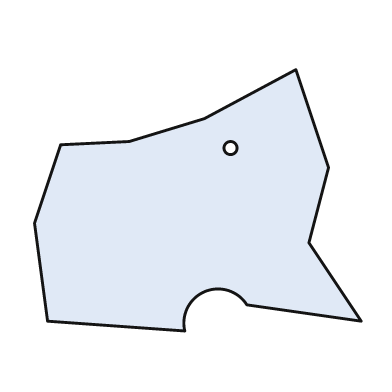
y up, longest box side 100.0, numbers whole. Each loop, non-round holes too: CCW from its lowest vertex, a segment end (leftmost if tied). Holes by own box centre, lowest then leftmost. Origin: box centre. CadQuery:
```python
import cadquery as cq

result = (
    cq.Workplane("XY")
    .moveTo(-4.0, -40.0)
    .threePointArc((2.0, -28.0), (15.0, -32.0))
    .lineTo(50.0, -37.0)
    .lineTo(34.0, -13.0)
    .lineTo(40.0, 10.0)
    .lineTo(30.0, 40.0)
    .lineTo(2.0, 25.0)
    .lineTo(-21.0, 18.0)
    .lineTo(-42.0, 17.0)
    .lineTo(-50.0, -7.0)
    .lineTo(-46.0, -37.0)
    .close()
    .moveTo(10.0, 16.0)
    .circle(2.0)
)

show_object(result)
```